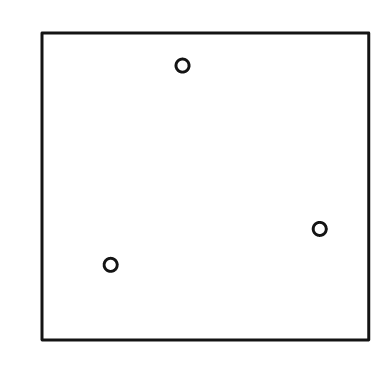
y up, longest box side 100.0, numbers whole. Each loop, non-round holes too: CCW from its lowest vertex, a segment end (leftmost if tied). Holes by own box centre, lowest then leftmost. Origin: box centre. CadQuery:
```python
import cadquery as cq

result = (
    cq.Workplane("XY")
    .moveTo(-50.0, -47.0)
    .lineTo(50.0, -47.0)
    .lineTo(50.0, 47.0)
    .lineTo(-50.0, 47.0)
    .close()
    .moveTo(-29.0, -24.0)
    .circle(2.0)
    .moveTo(35.0, -13.0)
    .circle(2.0)
    .moveTo(-7.0, 37.0)
    .circle(2.0)
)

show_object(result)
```